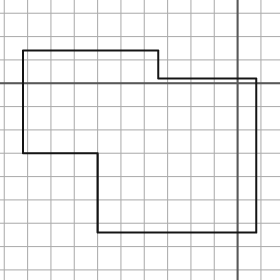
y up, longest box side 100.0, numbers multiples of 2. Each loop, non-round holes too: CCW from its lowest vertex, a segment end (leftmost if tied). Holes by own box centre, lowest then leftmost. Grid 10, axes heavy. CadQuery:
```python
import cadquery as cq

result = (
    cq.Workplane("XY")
    .moveTo(-60.0, -64.0)
    .lineTo(8.0, -64.0)
    .lineTo(8.0, 2.0)
    .lineTo(-34.0, 2.0)
    .lineTo(-34.0, 14.0)
    .lineTo(-92.0, 14.0)
    .lineTo(-92.0, -30.0)
    .lineTo(-60.0, -30.0)
    .close()
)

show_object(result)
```